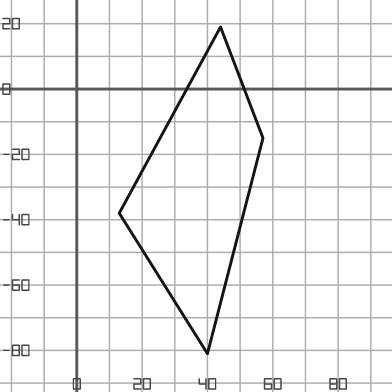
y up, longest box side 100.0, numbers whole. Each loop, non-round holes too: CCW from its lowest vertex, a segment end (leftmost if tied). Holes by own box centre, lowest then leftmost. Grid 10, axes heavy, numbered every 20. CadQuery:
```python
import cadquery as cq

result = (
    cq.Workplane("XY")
    .moveTo(40.0, -81.0)
    .lineTo(57.0, -15.0)
    .lineTo(44.0, 19.0)
    .lineTo(13.0, -38.0)
    .close()
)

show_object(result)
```